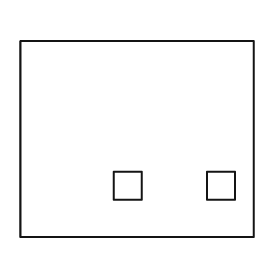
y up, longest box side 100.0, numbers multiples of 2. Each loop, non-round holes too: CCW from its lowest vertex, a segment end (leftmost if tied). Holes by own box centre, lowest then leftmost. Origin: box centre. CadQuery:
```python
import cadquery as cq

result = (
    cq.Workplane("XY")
    .moveTo(-50.0, -42.0)
    .lineTo(50.0, -42.0)
    .lineTo(50.0, 42.0)
    .lineTo(-50.0, 42.0)
    .close()
    .moveTo(-10.0, -26.0)
    .lineTo(2.0, -26.0)
    .lineTo(2.0, -14.0)
    .lineTo(-10.0, -14.0)
    .close()
    .moveTo(30.0, -26.0)
    .lineTo(42.0, -26.0)
    .lineTo(42.0, -14.0)
    .lineTo(30.0, -14.0)
    .close()
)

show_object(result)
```